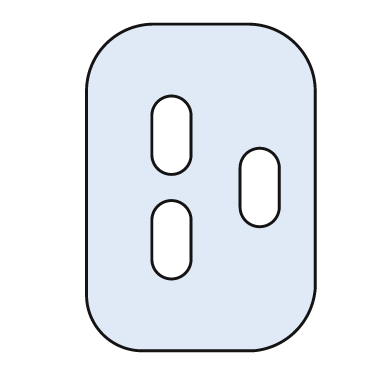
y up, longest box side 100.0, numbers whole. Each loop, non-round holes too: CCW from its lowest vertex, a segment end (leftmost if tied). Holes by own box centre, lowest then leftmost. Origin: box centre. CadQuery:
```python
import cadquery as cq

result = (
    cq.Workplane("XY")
    .moveTo(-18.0, -50.0)
    .lineTo(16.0, -50.0)
    .threePointArc((29.0, -44.0), (35.0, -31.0))
    .lineTo(35.0, 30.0)
    .threePointArc((29.0, 44.0), (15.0, 50.0))
    .lineTo(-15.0, 50.0)
    .threePointArc((-29.0, 44.0), (-35.0, 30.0))
    .lineTo(-35.0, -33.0)
    .threePointArc((-30.0, -45.0), (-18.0, -50.0))
    .close()
    .moveTo(-15.0, -22.0)
    .threePointArc((-9.0, -28.0), (-3.0, -22.0))
    .lineTo(-3.0, -10.0)
    .threePointArc((-9.0, -4.0), (-15.0, -10.0))
    .close()
    .moveTo(12.0, -6.0)
    .threePointArc((18.0, -12.0), (24.0, -6.0))
    .lineTo(24.0, 6.0)
    .threePointArc((18.0, 12.0), (12.0, 6.0))
    .close()
    .moveTo(-15.0, 10.0)
    .threePointArc((-9.0, 4.0), (-3.0, 10.0))
    .lineTo(-3.0, 22.0)
    .threePointArc((-9.0, 28.0), (-15.0, 22.0))
    .close()
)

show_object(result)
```